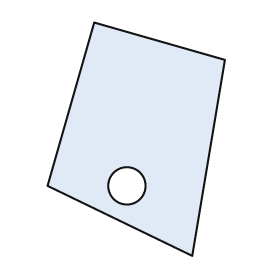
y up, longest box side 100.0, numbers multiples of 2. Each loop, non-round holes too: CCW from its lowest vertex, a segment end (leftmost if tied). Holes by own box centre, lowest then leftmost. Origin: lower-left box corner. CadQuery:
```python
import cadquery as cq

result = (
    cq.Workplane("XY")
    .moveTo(62.0, 0.0)
    .lineTo(76.0, 84.0)
    .lineTo(20.0, 100.0)
    .lineTo(0.0, 30.0)
    .close()
    .moveTo(34.0, 30.0)
    .circle(8.0)
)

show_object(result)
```